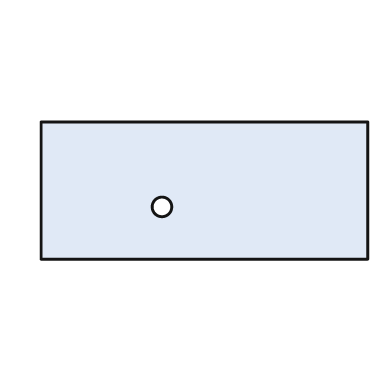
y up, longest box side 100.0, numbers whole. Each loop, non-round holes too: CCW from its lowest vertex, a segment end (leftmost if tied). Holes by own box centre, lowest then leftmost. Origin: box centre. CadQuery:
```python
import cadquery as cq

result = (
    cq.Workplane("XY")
    .moveTo(-50.0, -21.0)
    .lineTo(50.0, -21.0)
    .lineTo(50.0, 21.0)
    .lineTo(-50.0, 21.0)
    .close()
    .moveTo(-13.0, -5.0)
    .circle(3.0)
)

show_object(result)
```